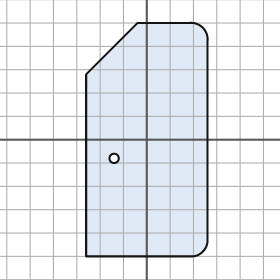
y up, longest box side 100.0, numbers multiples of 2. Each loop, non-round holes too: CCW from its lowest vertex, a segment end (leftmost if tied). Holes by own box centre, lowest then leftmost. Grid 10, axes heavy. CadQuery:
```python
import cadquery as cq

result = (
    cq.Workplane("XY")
    .moveTo(-26.0, -50.0)
    .lineTo(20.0, -50.0)
    .threePointArc((24.0, -48.0), (26.0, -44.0))
    .lineTo(26.0, 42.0)
    .threePointArc((24.0, 48.0), (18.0, 50.0))
    .lineTo(-4.0, 50.0)
    .lineTo(-26.0, 28.0)
    .close()
    .moveTo(-14.0, -8.0)
    .circle(2.0)
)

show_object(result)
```